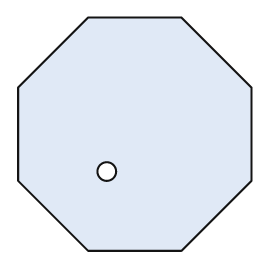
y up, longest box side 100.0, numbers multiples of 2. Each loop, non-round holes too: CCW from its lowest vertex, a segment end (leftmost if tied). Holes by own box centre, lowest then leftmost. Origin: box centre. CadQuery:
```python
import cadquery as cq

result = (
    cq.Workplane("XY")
    .moveTo(-20.0, -50.0)
    .lineTo(20.0, -50.0)
    .lineTo(50.0, -20.0)
    .lineTo(50.0, 20.0)
    .lineTo(20.0, 50.0)
    .lineTo(-20.0, 50.0)
    .lineTo(-50.0, 20.0)
    .lineTo(-50.0, -20.0)
    .close()
    .moveTo(-12.0, -16.0)
    .circle(4.0)
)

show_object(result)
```